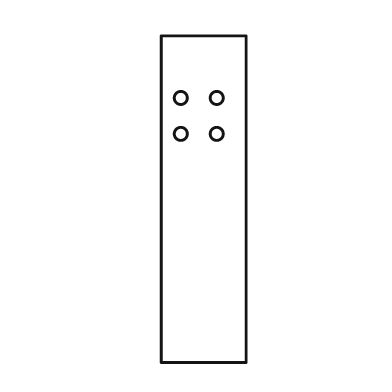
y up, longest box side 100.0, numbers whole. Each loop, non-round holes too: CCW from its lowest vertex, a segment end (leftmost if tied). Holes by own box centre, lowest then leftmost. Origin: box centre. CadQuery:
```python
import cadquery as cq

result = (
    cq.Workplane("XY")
    .moveTo(-13.0, -50.0)
    .lineTo(13.0, -50.0)
    .lineTo(13.0, 50.0)
    .lineTo(-13.0, 50.0)
    .close()
    .moveTo(-7.0, 20.0)
    .circle(2.0)
    .moveTo(4.0, 20.0)
    .circle(2.0)
    .moveTo(-7.0, 31.0)
    .circle(2.0)
    .moveTo(4.0, 31.0)
    .circle(2.0)
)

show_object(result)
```